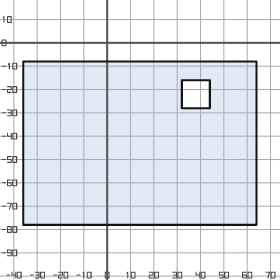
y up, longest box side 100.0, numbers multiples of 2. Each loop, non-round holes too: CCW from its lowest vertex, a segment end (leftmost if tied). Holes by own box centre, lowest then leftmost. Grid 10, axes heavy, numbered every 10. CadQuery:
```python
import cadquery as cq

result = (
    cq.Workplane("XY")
    .moveTo(-36.0, -78.0)
    .lineTo(64.0, -78.0)
    .lineTo(64.0, -8.0)
    .lineTo(-36.0, -8.0)
    .close()
    .moveTo(32.0, -28.0)
    .lineTo(44.0, -28.0)
    .lineTo(44.0, -16.0)
    .lineTo(32.0, -16.0)
    .close()
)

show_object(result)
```